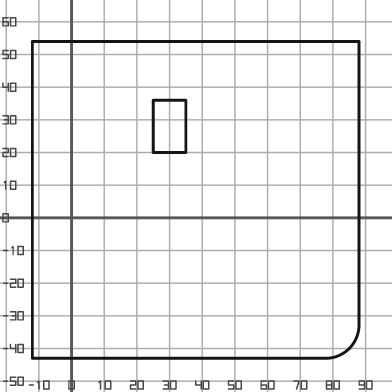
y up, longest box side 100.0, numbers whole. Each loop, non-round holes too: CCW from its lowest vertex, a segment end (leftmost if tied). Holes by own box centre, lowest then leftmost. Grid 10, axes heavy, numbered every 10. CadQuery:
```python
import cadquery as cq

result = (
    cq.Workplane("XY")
    .moveTo(-12.0, -43.0)
    .lineTo(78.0, -43.0)
    .threePointArc((85.0, -40.0), (88.0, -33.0))
    .lineTo(88.0, 54.0)
    .lineTo(-12.0, 54.0)
    .close()
    .moveTo(25.0, 20.0)
    .lineTo(35.0, 20.0)
    .lineTo(35.0, 36.0)
    .lineTo(25.0, 36.0)
    .close()
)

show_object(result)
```